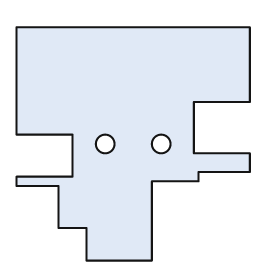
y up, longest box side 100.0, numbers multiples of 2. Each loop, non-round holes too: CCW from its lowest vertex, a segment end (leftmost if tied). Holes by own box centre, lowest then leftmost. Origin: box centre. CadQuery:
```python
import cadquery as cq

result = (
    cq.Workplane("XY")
    .moveTo(-20.0, -50.0)
    .lineTo(8.0, -50.0)
    .lineTo(8.0, -16.0)
    .lineTo(28.0, -16.0)
    .lineTo(28.0, -12.0)
    .lineTo(50.0, -12.0)
    .lineTo(50.0, -4.0)
    .lineTo(26.0, -4.0)
    .lineTo(26.0, 18.0)
    .lineTo(50.0, 18.0)
    .lineTo(50.0, 50.0)
    .lineTo(-50.0, 50.0)
    .lineTo(-50.0, 4.0)
    .lineTo(-26.0, 4.0)
    .lineTo(-26.0, -14.0)
    .lineTo(-50.0, -14.0)
    .lineTo(-50.0, -18.0)
    .lineTo(-32.0, -18.0)
    .lineTo(-32.0, -36.0)
    .lineTo(-20.0, -36.0)
    .close()
    .moveTo(-12.0, 0.0)
    .circle(4.0)
    .moveTo(12.0, 0.0)
    .circle(4.0)
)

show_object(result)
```